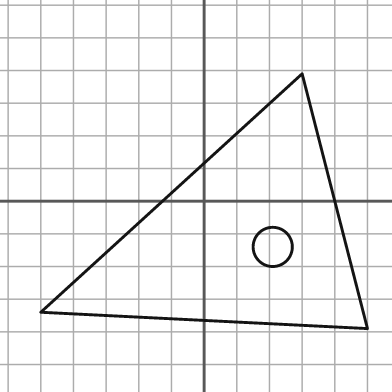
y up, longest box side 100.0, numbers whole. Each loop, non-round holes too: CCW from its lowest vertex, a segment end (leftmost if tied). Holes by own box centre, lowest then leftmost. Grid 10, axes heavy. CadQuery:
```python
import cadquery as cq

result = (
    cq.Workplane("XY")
    .moveTo(50.0, -39.0)
    .lineTo(30.0, 39.0)
    .lineTo(-50.0, -34.0)
    .close()
    .moveTo(21.0, -14.0)
    .circle(6.0)
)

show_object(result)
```